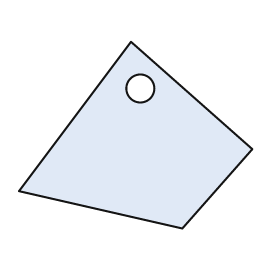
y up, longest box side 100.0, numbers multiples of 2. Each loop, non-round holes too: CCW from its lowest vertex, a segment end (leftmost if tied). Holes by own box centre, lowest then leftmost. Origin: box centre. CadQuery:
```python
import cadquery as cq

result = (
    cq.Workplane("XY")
    .moveTo(20.0, -40.0)
    .lineTo(50.0, -6.0)
    .lineTo(-2.0, 40.0)
    .lineTo(-50.0, -24.0)
    .close()
    .moveTo(2.0, 20.0)
    .circle(6.0)
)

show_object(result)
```